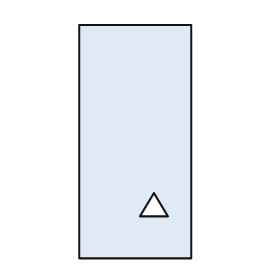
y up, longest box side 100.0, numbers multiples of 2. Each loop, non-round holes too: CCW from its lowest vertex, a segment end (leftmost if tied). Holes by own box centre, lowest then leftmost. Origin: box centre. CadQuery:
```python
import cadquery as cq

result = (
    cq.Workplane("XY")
    .moveTo(-24.0, -50.0)
    .lineTo(24.0, -50.0)
    .lineTo(24.0, 50.0)
    .lineTo(-24.0, 50.0)
    .close()
    .moveTo(2.0, -32.0)
    .lineTo(14.0, -32.0)
    .lineTo(8.0, -22.0)
    .close()
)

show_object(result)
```